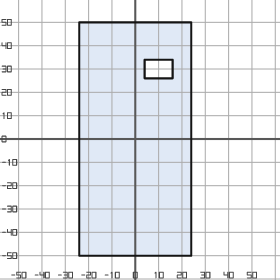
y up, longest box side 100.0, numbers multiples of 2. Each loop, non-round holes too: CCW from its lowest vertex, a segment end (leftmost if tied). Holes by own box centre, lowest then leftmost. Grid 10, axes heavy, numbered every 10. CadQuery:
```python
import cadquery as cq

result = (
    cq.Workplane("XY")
    .moveTo(-24.0, -50.0)
    .lineTo(24.0, -50.0)
    .lineTo(24.0, 50.0)
    .lineTo(-24.0, 50.0)
    .close()
    .moveTo(4.0, 26.0)
    .lineTo(16.0, 26.0)
    .lineTo(16.0, 34.0)
    .lineTo(4.0, 34.0)
    .close()
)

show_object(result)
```